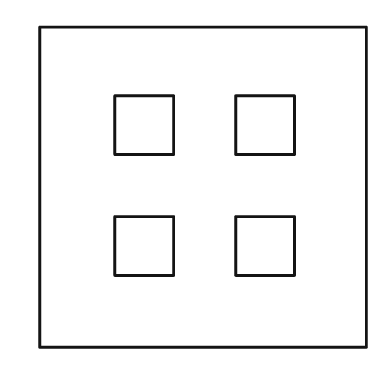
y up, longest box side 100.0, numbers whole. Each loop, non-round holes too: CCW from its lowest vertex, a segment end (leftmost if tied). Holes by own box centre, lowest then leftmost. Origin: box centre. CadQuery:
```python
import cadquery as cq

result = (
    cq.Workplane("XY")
    .moveTo(-50.0, -49.0)
    .lineTo(50.0, -49.0)
    .lineTo(50.0, 49.0)
    .lineTo(-50.0, 49.0)
    .close()
    .moveTo(-27.0, -27.0)
    .lineTo(-9.0, -27.0)
    .lineTo(-9.0, -9.0)
    .lineTo(-27.0, -9.0)
    .close()
    .moveTo(10.0, -27.0)
    .lineTo(28.0, -27.0)
    .lineTo(28.0, -9.0)
    .lineTo(10.0, -9.0)
    .close()
    .moveTo(-27.0, 10.0)
    .lineTo(-9.0, 10.0)
    .lineTo(-9.0, 28.0)
    .lineTo(-27.0, 28.0)
    .close()
    .moveTo(10.0, 10.0)
    .lineTo(28.0, 10.0)
    .lineTo(28.0, 28.0)
    .lineTo(10.0, 28.0)
    .close()
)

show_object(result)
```